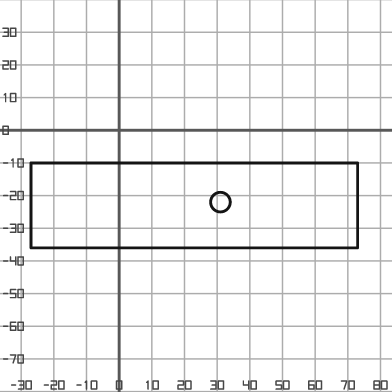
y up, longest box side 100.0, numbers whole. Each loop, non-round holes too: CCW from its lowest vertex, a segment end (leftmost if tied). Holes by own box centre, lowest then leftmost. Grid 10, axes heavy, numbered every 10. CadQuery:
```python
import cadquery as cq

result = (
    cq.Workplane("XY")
    .moveTo(-27.0, -36.0)
    .lineTo(73.0, -36.0)
    .lineTo(73.0, -10.0)
    .lineTo(-27.0, -10.0)
    .close()
    .moveTo(31.0, -22.0)
    .circle(3.0)
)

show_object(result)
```